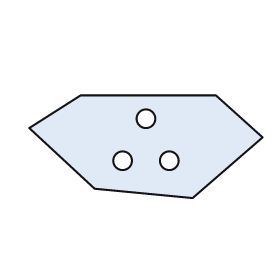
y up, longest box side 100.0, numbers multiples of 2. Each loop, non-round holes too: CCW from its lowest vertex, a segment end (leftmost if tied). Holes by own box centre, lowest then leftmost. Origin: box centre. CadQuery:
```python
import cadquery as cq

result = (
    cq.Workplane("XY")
    .moveTo(20.0, -22.0)
    .lineTo(50.0, 4.0)
    .lineTo(30.0, 22.0)
    .lineTo(-28.0, 22.0)
    .lineTo(-50.0, 8.0)
    .lineTo(-22.0, -18.0)
    .close()
    .moveTo(-10.0, -6.0)
    .circle(4.0)
    .moveTo(10.0, -6.0)
    .circle(4.0)
    .moveTo(0.0, 12.0)
    .circle(4.0)
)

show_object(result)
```